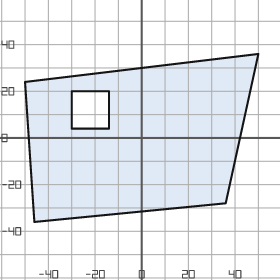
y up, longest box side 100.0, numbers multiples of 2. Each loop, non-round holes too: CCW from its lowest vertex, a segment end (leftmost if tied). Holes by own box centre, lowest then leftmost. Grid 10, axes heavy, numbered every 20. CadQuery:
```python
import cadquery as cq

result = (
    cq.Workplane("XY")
    .moveTo(-46.0, -36.0)
    .lineTo(36.0, -28.0)
    .lineTo(50.0, 36.0)
    .lineTo(-50.0, 24.0)
    .close()
    .moveTo(-30.0, 4.0)
    .lineTo(-14.0, 4.0)
    .lineTo(-14.0, 20.0)
    .lineTo(-30.0, 20.0)
    .close()
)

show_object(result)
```